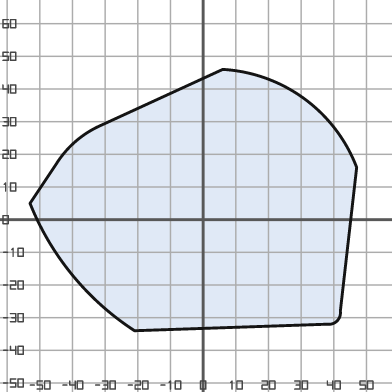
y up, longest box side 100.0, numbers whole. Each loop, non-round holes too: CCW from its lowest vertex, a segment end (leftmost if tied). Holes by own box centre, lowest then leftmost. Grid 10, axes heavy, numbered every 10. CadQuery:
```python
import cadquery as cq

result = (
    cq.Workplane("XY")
    .moveTo(-21.0, -34.0)
    .lineTo(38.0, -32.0)
    .threePointArc((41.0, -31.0), (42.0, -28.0))
    .lineTo(47.0, 16.0)
    .threePointArc((31.0, 37.0), (6.0, 46.0))
    .lineTo(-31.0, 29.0)
    .threePointArc((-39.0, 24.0), (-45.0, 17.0))
    .lineTo(-53.0, 5.0)
    .threePointArc((-40.0, -17.0), (-21.0, -34.0))
    .close()
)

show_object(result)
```